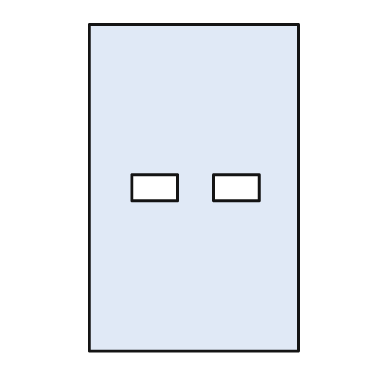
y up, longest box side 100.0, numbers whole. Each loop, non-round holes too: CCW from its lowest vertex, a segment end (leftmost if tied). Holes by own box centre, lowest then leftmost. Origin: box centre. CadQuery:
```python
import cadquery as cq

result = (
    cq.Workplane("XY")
    .moveTo(-32.0, -50.0)
    .lineTo(32.0, -50.0)
    .lineTo(32.0, 50.0)
    .lineTo(-32.0, 50.0)
    .close()
    .moveTo(-19.0, -4.0)
    .lineTo(-5.0, -4.0)
    .lineTo(-5.0, 4.0)
    .lineTo(-19.0, 4.0)
    .close()
    .moveTo(6.0, -4.0)
    .lineTo(20.0, -4.0)
    .lineTo(20.0, 4.0)
    .lineTo(6.0, 4.0)
    .close()
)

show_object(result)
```